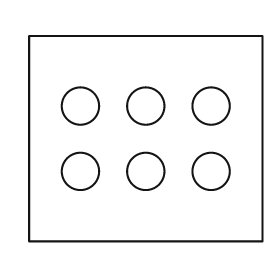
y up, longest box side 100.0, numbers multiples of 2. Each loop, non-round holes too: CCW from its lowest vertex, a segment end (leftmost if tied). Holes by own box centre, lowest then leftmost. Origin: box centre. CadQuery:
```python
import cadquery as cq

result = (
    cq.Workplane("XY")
    .moveTo(-50.0, -44.0)
    .lineTo(50.0, -44.0)
    .lineTo(50.0, 44.0)
    .lineTo(-50.0, 44.0)
    .close()
    .moveTo(-28.0, -14.0)
    .circle(8.0)
    .moveTo(0.0, -14.0)
    .circle(8.0)
    .moveTo(28.0, -14.0)
    .circle(8.0)
    .moveTo(-28.0, 14.0)
    .circle(8.0)
    .moveTo(0.0, 14.0)
    .circle(8.0)
    .moveTo(28.0, 14.0)
    .circle(8.0)
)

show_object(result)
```